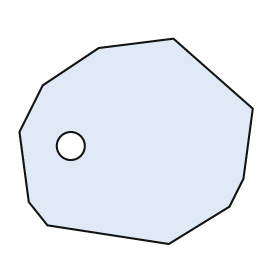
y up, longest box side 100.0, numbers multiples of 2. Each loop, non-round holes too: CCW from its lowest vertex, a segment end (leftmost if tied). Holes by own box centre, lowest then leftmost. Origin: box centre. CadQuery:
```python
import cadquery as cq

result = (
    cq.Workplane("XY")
    .moveTo(14.0, -44.0)
    .lineTo(40.0, -28.0)
    .lineTo(46.0, -16.0)
    .lineTo(50.0, 14.0)
    .lineTo(16.0, 44.0)
    .lineTo(-16.0, 40.0)
    .lineTo(-40.0, 24.0)
    .lineTo(-50.0, 4.0)
    .lineTo(-46.0, -26.0)
    .lineTo(-38.0, -36.0)
    .close()
    .moveTo(-28.0, -2.0)
    .circle(6.0)
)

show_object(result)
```